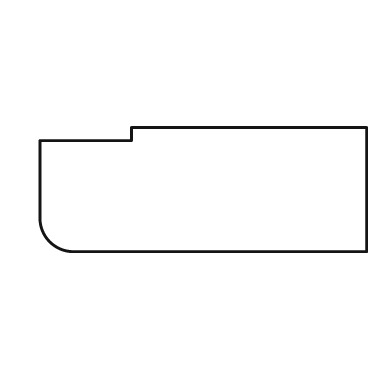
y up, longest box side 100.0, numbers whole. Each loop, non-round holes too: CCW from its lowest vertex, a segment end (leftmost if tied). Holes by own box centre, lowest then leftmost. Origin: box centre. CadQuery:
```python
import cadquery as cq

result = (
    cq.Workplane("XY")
    .moveTo(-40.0, -19.0)
    .lineTo(50.0, -19.0)
    .lineTo(50.0, 19.0)
    .lineTo(-22.0, 19.0)
    .lineTo(-22.0, 15.0)
    .lineTo(-50.0, 15.0)
    .lineTo(-50.0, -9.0)
    .threePointArc((-47.0, -16.0), (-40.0, -19.0))
    .close()
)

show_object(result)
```